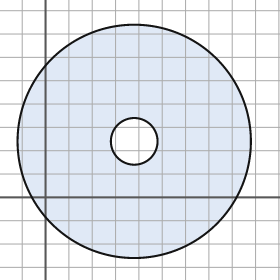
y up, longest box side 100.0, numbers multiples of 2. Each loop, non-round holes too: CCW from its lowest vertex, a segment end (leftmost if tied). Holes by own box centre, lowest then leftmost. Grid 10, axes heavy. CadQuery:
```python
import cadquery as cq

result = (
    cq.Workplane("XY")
    .moveTo(38.0, 24.0)
    .circle(50.0)
    .moveTo(38.0, 24.0)
    .circle(10.0)
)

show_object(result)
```